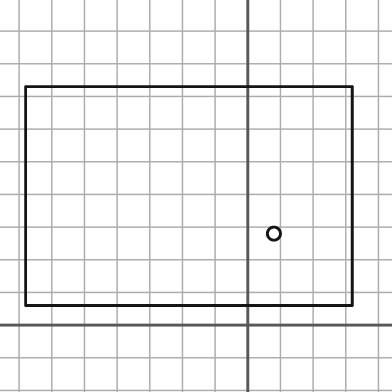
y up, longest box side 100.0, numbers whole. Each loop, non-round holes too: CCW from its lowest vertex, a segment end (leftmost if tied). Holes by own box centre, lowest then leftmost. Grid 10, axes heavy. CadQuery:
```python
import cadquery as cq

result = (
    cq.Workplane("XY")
    .moveTo(-68.0, 6.0)
    .lineTo(32.0, 6.0)
    .lineTo(32.0, 73.0)
    .lineTo(-68.0, 73.0)
    .close()
    .moveTo(8.0, 28.0)
    .circle(2.0)
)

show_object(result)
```